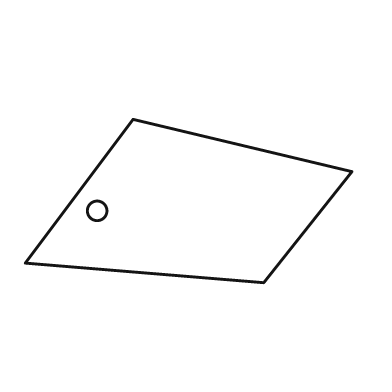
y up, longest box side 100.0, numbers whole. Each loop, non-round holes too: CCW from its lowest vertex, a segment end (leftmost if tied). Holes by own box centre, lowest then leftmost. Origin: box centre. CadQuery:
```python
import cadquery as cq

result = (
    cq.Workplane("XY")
    .moveTo(23.0, -25.0)
    .lineTo(50.0, 9.0)
    .lineTo(-17.0, 25.0)
    .lineTo(-50.0, -19.0)
    .close()
    .moveTo(-28.0, -3.0)
    .circle(3.0)
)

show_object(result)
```